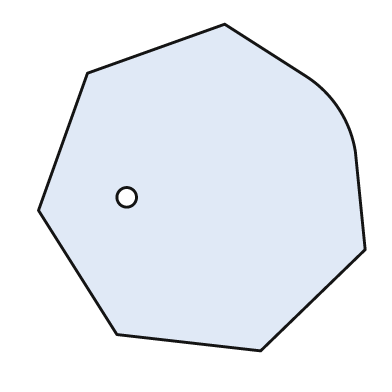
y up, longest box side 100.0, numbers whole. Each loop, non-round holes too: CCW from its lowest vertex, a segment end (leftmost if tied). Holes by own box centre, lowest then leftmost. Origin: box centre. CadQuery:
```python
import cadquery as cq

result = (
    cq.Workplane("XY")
    .moveTo(18.0, -50.0)
    .lineTo(50.0, -19.0)
    .lineTo(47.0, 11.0)
    .threePointArc((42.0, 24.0), (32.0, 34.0))
    .lineTo(7.0, 50.0)
    .lineTo(-35.0, 35.0)
    .lineTo(-50.0, -7.0)
    .lineTo(-26.0, -45.0)
    .close()
    .moveTo(-23.0, -3.0)
    .circle(3.0)
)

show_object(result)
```